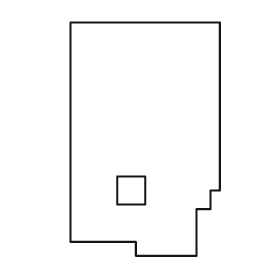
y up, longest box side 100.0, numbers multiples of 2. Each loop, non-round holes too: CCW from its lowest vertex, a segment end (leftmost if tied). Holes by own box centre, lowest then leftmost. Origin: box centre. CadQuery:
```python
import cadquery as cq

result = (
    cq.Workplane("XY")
    .moveTo(-4.0, -50.0)
    .lineTo(22.0, -50.0)
    .lineTo(22.0, -30.0)
    .lineTo(28.0, -30.0)
    .lineTo(28.0, -22.0)
    .lineTo(32.0, -22.0)
    .lineTo(32.0, 50.0)
    .lineTo(-32.0, 50.0)
    .lineTo(-32.0, -44.0)
    .lineTo(-4.0, -44.0)
    .close()
    .moveTo(-12.0, -28.0)
    .lineTo(0.0, -28.0)
    .lineTo(0.0, -16.0)
    .lineTo(-12.0, -16.0)
    .close()
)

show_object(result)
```